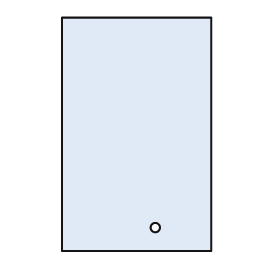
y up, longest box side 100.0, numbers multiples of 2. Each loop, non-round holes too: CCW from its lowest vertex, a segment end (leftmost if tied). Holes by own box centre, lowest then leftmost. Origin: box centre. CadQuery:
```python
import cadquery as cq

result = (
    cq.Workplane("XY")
    .moveTo(-32.0, -50.0)
    .lineTo(32.0, -50.0)
    .lineTo(32.0, 50.0)
    .lineTo(-32.0, 50.0)
    .close()
    .moveTo(8.0, -40.0)
    .circle(2.0)
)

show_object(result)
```